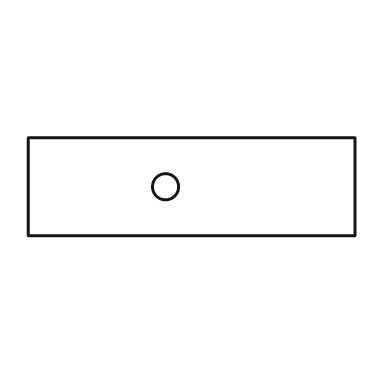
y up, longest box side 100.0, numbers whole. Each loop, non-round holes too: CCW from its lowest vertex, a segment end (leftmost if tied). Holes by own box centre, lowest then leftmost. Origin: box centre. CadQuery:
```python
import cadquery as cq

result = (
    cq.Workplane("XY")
    .moveTo(-50.0, -15.0)
    .lineTo(50.0, -15.0)
    .lineTo(50.0, 15.0)
    .lineTo(-50.0, 15.0)
    .close()
    .moveTo(-8.0, 0.0)
    .circle(4.0)
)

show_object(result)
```